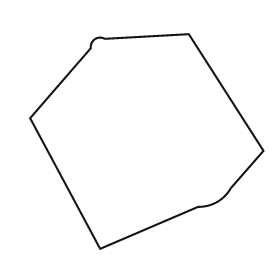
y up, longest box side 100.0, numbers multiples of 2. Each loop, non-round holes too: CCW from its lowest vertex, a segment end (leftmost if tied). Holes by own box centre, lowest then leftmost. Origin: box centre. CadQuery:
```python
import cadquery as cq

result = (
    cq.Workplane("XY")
    .moveTo(-20.0, -46.0)
    .lineTo(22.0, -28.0)
    .threePointArc((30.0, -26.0), (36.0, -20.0))
    .lineTo(50.0, -4.0)
    .lineTo(18.0, 46.0)
    .lineTo(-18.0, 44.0)
    .threePointArc((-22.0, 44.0), (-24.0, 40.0))
    .lineTo(-50.0, 10.0)
    .close()
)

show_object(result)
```